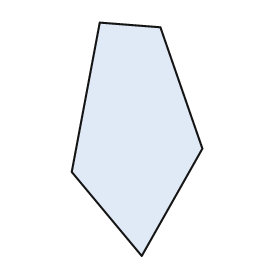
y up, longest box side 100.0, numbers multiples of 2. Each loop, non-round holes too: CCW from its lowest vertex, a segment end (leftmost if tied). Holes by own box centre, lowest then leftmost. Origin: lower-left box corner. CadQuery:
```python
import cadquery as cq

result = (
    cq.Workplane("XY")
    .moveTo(30.0, 0.0)
    .lineTo(56.0, 46.0)
    .lineTo(38.0, 98.0)
    .lineTo(12.0, 100.0)
    .lineTo(0.0, 36.0)
    .close()
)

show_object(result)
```